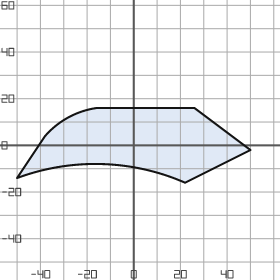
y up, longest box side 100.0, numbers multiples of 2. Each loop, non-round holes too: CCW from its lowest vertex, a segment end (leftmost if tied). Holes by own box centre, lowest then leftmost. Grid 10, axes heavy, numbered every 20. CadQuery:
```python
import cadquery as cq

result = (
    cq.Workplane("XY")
    .moveTo(22.0, -16.0)
    .lineTo(50.0, -2.0)
    .lineTo(26.0, 16.0)
    .lineTo(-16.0, 16.0)
    .threePointArc((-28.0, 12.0), (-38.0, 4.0))
    .lineTo(-50.0, -14.0)
    .threePointArc((-14.0, -8.0), (22.0, -16.0))
    .close()
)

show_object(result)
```